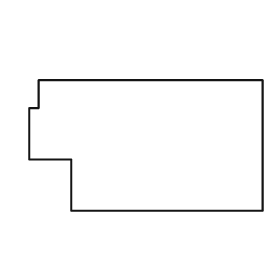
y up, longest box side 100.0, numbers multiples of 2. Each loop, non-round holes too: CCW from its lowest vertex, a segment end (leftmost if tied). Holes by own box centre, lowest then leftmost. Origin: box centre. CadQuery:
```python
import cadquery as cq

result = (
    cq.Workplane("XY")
    .moveTo(-32.0, -28.0)
    .lineTo(50.0, -28.0)
    .lineTo(50.0, 28.0)
    .lineTo(-46.0, 28.0)
    .lineTo(-46.0, 16.0)
    .lineTo(-50.0, 16.0)
    .lineTo(-50.0, -6.0)
    .lineTo(-32.0, -6.0)
    .close()
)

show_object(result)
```